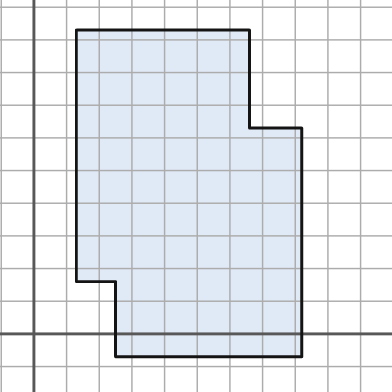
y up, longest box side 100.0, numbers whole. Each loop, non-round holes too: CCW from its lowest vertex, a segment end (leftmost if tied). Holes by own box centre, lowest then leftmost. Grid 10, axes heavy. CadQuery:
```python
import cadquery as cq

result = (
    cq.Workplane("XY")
    .moveTo(25.0, -7.0)
    .lineTo(82.0, -7.0)
    .lineTo(82.0, 63.0)
    .lineTo(66.0, 63.0)
    .lineTo(66.0, 93.0)
    .lineTo(13.0, 93.0)
    .lineTo(13.0, 16.0)
    .lineTo(25.0, 16.0)
    .close()
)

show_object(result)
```